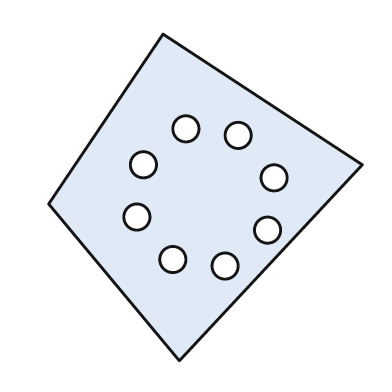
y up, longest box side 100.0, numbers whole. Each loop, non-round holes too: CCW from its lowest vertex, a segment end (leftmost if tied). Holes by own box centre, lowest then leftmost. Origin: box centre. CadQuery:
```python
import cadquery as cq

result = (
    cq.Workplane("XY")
    .moveTo(-8.0, -50.0)
    .lineTo(48.0, 10.0)
    .lineTo(-13.0, 50.0)
    .lineTo(-48.0, -2.0)
    .close()
    .moveTo(6.0, -21.0)
    .circle(4.0)
    .moveTo(-10.0, -19.0)
    .circle(4.0)
    .moveTo(19.0, -10.0)
    .circle(4.0)
    .moveTo(-21.0, -6.0)
    .circle(4.0)
    .moveTo(21.0, 6.0)
    .circle(4.0)
    .moveTo(-19.0, 10.0)
    .circle(4.0)
    .moveTo(10.0, 19.0)
    .circle(4.0)
    .moveTo(-6.0, 21.0)
    .circle(4.0)
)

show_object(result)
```